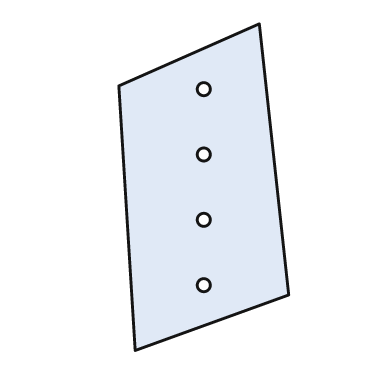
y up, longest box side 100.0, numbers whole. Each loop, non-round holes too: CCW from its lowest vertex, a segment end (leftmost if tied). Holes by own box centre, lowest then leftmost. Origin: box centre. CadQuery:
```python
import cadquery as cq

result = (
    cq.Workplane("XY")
    .moveTo(-21.0, -50.0)
    .lineTo(26.0, -33.0)
    .lineTo(17.0, 50.0)
    .lineTo(-26.0, 31.0)
    .close()
    .moveTo(0.0, -30.0)
    .circle(2.0)
    .moveTo(0.0, -10.0)
    .circle(2.0)
    .moveTo(0.0, 10.0)
    .circle(2.0)
    .moveTo(0.0, 30.0)
    .circle(2.0)
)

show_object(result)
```